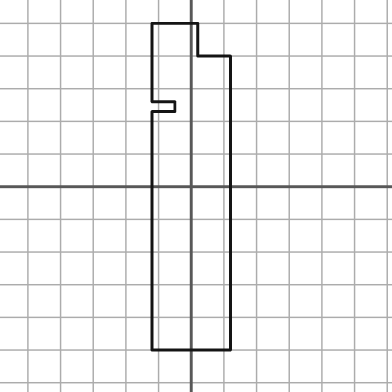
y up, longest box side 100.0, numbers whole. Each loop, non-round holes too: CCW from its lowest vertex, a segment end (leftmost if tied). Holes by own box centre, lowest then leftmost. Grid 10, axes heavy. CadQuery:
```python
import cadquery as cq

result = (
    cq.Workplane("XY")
    .moveTo(-12.0, -50.0)
    .lineTo(12.0, -50.0)
    .lineTo(12.0, 40.0)
    .lineTo(2.0, 40.0)
    .lineTo(2.0, 50.0)
    .lineTo(-12.0, 50.0)
    .lineTo(-12.0, 26.0)
    .lineTo(-5.0, 26.0)
    .lineTo(-5.0, 23.0)
    .lineTo(-12.0, 23.0)
    .close()
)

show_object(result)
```